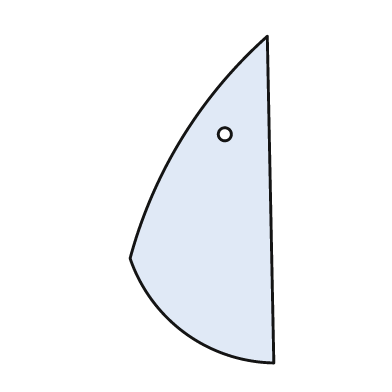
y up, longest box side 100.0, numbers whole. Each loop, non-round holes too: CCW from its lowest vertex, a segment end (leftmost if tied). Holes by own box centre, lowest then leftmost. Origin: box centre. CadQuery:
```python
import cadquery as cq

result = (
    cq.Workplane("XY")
    .moveTo(22.0, -50.0)
    .lineTo(20.0, 50.0)
    .threePointArc((-6.0, 19.0), (-22.0, -18.0))
    .threePointArc((-5.0, -41.0), (22.0, -50.0))
    .close()
    .moveTo(7.0, 20.0)
    .circle(2.0)
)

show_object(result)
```